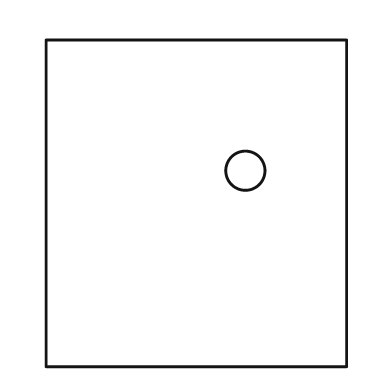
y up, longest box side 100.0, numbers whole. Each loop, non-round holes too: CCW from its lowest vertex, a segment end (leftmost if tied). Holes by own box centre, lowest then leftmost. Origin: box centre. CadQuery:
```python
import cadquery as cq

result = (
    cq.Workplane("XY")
    .moveTo(-46.0, -50.0)
    .lineTo(46.0, -50.0)
    .lineTo(46.0, 50.0)
    .lineTo(-46.0, 50.0)
    .close()
    .moveTo(15.0, 10.0)
    .circle(6.0)
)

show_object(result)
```